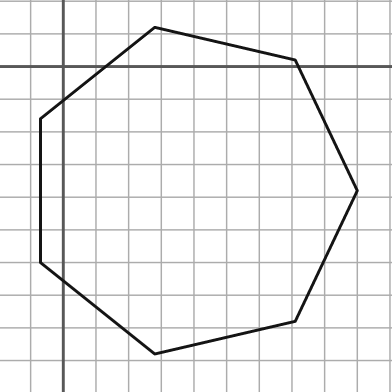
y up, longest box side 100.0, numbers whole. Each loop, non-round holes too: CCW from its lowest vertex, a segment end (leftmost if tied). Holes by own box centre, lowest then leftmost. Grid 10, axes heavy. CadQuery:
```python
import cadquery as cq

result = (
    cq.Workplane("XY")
    .moveTo(28.0, -88.0)
    .lineTo(71.0, -78.0)
    .lineTo(90.0, -38.0)
    .lineTo(71.0, 2.0)
    .lineTo(28.0, 12.0)
    .lineTo(-7.0, -16.0)
    .lineTo(-7.0, -60.0)
    .close()
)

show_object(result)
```